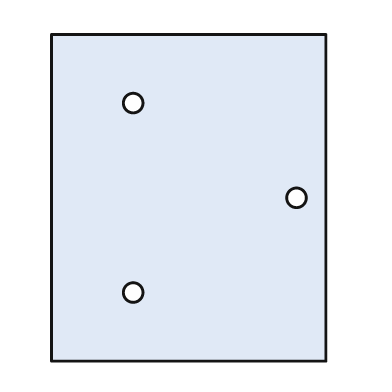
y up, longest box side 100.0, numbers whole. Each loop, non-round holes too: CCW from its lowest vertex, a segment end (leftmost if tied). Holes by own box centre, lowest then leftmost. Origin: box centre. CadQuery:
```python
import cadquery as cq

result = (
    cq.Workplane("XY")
    .moveTo(-42.0, -50.0)
    .lineTo(42.0, -50.0)
    .lineTo(42.0, 50.0)
    .lineTo(-42.0, 50.0)
    .close()
    .moveTo(-17.0, -29.0)
    .circle(3.0)
    .moveTo(33.0, 0.0)
    .circle(3.0)
    .moveTo(-17.0, 29.0)
    .circle(3.0)
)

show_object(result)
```